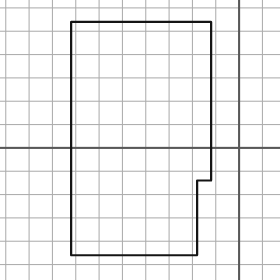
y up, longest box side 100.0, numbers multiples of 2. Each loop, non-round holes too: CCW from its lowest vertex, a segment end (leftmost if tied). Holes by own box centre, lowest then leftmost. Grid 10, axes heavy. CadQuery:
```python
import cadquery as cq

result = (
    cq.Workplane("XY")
    .moveTo(-72.0, -46.0)
    .lineTo(-18.0, -46.0)
    .lineTo(-18.0, -14.0)
    .lineTo(-12.0, -14.0)
    .lineTo(-12.0, 54.0)
    .lineTo(-72.0, 54.0)
    .close()
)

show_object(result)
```